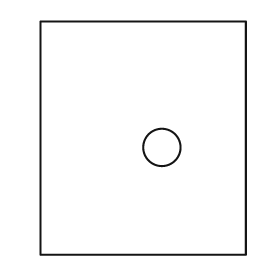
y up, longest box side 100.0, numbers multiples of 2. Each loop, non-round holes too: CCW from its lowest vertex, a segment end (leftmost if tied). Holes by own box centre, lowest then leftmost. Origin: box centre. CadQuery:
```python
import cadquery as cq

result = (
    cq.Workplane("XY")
    .moveTo(-44.0, -50.0)
    .lineTo(44.0, -50.0)
    .lineTo(44.0, 50.0)
    .lineTo(-44.0, 50.0)
    .close()
    .moveTo(8.0, -4.0)
    .circle(8.0)
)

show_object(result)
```